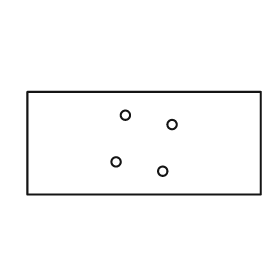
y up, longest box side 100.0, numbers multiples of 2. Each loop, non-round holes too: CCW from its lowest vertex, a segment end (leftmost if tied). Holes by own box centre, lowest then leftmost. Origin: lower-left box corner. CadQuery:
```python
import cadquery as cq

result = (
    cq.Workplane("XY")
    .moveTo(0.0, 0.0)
    .lineTo(100.0, 0.0)
    .lineTo(100.0, 44.0)
    .lineTo(0.0, 44.0)
    .close()
    .moveTo(58.0, 10.0)
    .circle(2.0)
    .moveTo(38.0, 14.0)
    .circle(2.0)
    .moveTo(62.0, 30.0)
    .circle(2.0)
    .moveTo(42.0, 34.0)
    .circle(2.0)
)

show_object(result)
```